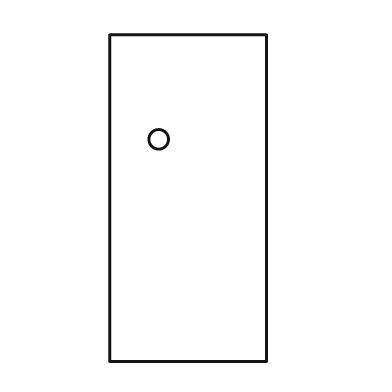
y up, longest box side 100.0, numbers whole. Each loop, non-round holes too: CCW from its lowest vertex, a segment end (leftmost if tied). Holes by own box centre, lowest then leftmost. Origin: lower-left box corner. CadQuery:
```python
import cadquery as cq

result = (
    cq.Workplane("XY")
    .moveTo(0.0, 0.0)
    .lineTo(48.0, 0.0)
    .lineTo(48.0, 100.0)
    .lineTo(0.0, 100.0)
    .close()
    .moveTo(15.0, 68.0)
    .circle(3.0)
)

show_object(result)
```